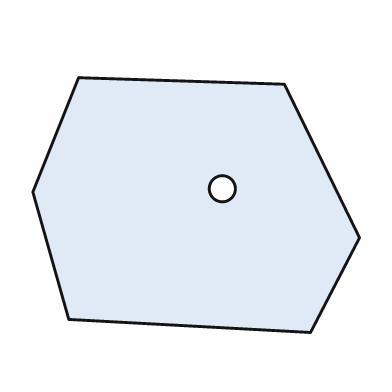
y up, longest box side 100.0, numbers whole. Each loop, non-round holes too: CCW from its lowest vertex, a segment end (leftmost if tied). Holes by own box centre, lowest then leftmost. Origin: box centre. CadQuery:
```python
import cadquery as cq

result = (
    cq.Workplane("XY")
    .moveTo(35.0, -39.0)
    .lineTo(50.0, -10.0)
    .lineTo(27.0, 37.0)
    .lineTo(-36.0, 39.0)
    .lineTo(-50.0, 4.0)
    .lineTo(-39.0, -35.0)
    .close()
    .moveTo(8.0, 5.0)
    .circle(4.0)
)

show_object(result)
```